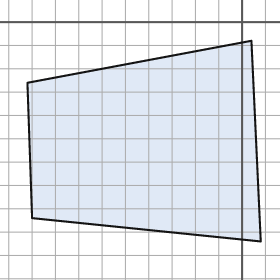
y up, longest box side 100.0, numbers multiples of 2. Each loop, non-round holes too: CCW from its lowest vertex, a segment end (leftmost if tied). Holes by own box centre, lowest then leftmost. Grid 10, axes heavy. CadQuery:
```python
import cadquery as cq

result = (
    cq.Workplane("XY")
    .moveTo(8.0, -94.0)
    .lineTo(4.0, -8.0)
    .lineTo(-92.0, -26.0)
    .lineTo(-90.0, -84.0)
    .close()
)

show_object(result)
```